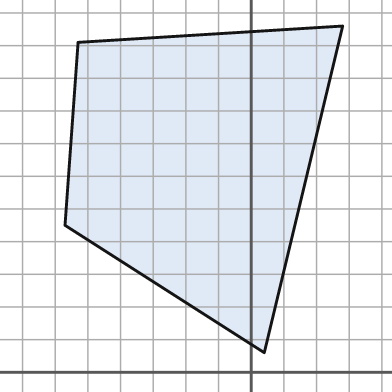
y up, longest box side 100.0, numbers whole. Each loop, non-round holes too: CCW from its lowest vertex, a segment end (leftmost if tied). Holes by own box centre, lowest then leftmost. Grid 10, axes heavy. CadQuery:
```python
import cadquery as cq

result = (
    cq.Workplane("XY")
    .moveTo(4.0, 6.0)
    .lineTo(28.0, 106.0)
    .lineTo(-53.0, 101.0)
    .lineTo(-57.0, 45.0)
    .close()
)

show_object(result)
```